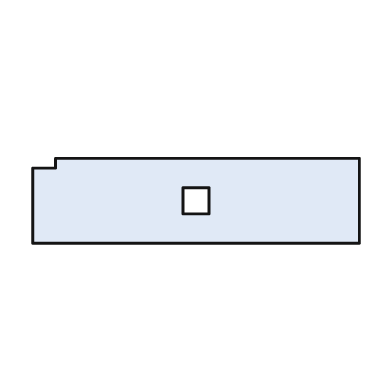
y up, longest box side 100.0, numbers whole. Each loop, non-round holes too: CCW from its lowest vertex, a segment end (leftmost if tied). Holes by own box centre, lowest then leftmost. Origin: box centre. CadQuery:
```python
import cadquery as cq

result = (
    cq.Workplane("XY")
    .moveTo(-50.0, -13.0)
    .lineTo(50.0, -13.0)
    .lineTo(50.0, 13.0)
    .lineTo(-43.0, 13.0)
    .lineTo(-43.0, 10.0)
    .lineTo(-50.0, 10.0)
    .close()
    .moveTo(-4.0, -4.0)
    .lineTo(4.0, -4.0)
    .lineTo(4.0, 4.0)
    .lineTo(-4.0, 4.0)
    .close()
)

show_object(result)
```